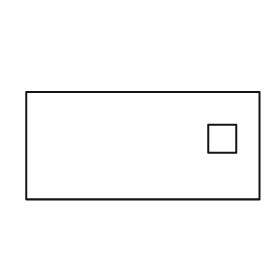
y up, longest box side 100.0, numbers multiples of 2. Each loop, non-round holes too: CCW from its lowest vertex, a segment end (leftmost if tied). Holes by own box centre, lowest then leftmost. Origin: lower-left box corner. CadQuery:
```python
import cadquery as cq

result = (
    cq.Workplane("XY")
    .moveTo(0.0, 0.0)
    .lineTo(100.0, 0.0)
    .lineTo(100.0, 46.0)
    .lineTo(0.0, 46.0)
    .close()
    .moveTo(78.0, 20.0)
    .lineTo(90.0, 20.0)
    .lineTo(90.0, 32.0)
    .lineTo(78.0, 32.0)
    .close()
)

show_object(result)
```